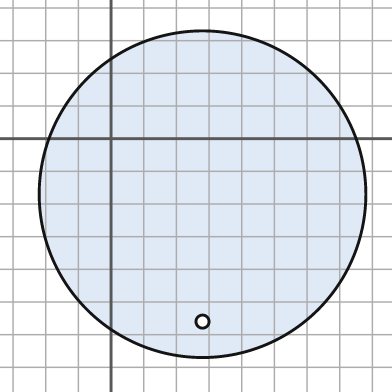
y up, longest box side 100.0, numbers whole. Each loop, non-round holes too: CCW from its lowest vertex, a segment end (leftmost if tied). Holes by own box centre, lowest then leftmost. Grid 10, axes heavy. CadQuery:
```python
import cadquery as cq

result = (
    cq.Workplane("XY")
    .moveTo(28.0, -17.0)
    .circle(50.0)
    .moveTo(28.0, -56.0)
    .circle(2.0)
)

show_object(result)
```